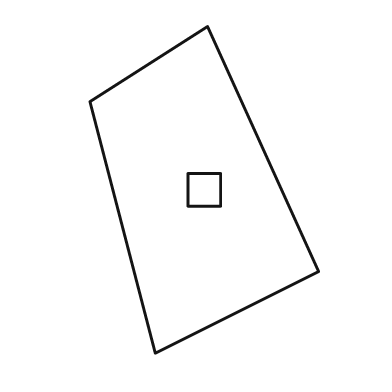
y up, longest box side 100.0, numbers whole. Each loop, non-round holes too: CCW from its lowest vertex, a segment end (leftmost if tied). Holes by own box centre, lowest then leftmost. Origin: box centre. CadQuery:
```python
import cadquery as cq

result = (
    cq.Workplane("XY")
    .moveTo(-15.0, -50.0)
    .lineTo(35.0, -25.0)
    .lineTo(1.0, 50.0)
    .lineTo(-35.0, 27.0)
    .close()
    .moveTo(-5.0, -5.0)
    .lineTo(5.0, -5.0)
    .lineTo(5.0, 5.0)
    .lineTo(-5.0, 5.0)
    .close()
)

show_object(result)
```